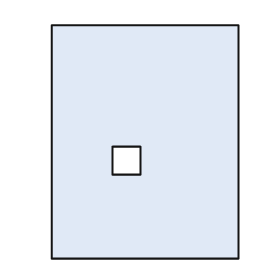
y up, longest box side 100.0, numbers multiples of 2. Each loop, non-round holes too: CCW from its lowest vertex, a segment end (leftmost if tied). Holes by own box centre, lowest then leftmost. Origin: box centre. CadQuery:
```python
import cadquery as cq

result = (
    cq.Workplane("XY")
    .moveTo(-40.0, -50.0)
    .lineTo(40.0, -50.0)
    .lineTo(40.0, 50.0)
    .lineTo(-40.0, 50.0)
    .close()
    .moveTo(-14.0, -14.0)
    .lineTo(-2.0, -14.0)
    .lineTo(-2.0, -2.0)
    .lineTo(-14.0, -2.0)
    .close()
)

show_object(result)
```